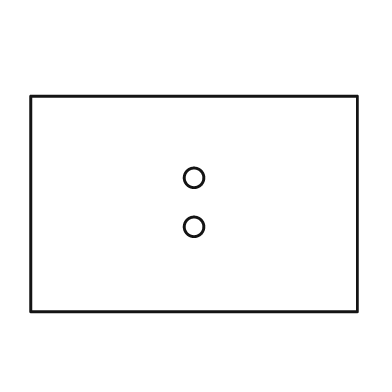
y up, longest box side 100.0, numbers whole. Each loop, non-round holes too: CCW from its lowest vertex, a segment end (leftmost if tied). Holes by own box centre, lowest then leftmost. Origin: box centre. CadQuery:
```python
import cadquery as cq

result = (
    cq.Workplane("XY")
    .moveTo(-50.0, -33.0)
    .lineTo(50.0, -33.0)
    .lineTo(50.0, 33.0)
    .lineTo(-50.0, 33.0)
    .close()
    .moveTo(0.0, -7.0)
    .circle(3.0)
    .moveTo(0.0, 8.0)
    .circle(3.0)
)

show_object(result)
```